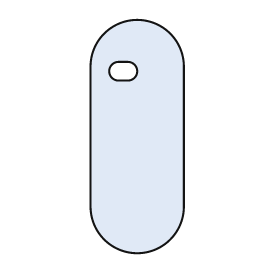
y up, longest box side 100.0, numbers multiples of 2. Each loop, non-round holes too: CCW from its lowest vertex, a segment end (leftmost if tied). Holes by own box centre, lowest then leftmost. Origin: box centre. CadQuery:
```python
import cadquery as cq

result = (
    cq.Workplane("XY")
    .moveTo(-20.0, -30.0)
    .threePointArc((0.0, -50.0), (20.0, -30.0))
    .lineTo(20.0, 30.0)
    .threePointArc((0.0, 50.0), (-20.0, 30.0))
    .close()
    .moveTo(-8.0, 24.0)
    .lineTo(-4.0, 24.0)
    .threePointArc((0.0, 28.0), (-4.0, 32.0))
    .lineTo(-8.0, 32.0)
    .threePointArc((-12.0, 28.0), (-8.0, 24.0))
    .close()
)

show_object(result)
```